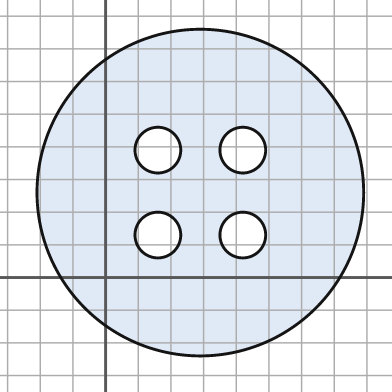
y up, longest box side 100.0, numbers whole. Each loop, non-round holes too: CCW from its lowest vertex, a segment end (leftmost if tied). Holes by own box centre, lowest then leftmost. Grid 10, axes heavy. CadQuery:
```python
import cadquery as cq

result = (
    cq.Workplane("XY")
    .moveTo(29.0, 26.0)
    .circle(50.0)
    .moveTo(16.0, 13.0)
    .circle(7.0)
    .moveTo(42.0, 13.0)
    .circle(7.0)
    .moveTo(16.0, 39.0)
    .circle(7.0)
    .moveTo(42.0, 39.0)
    .circle(7.0)
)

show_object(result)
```